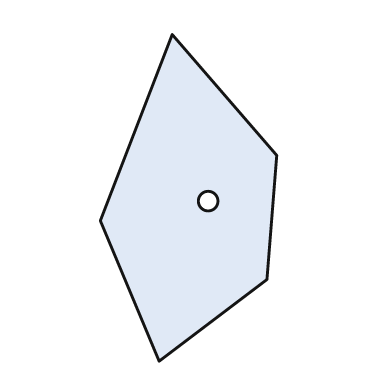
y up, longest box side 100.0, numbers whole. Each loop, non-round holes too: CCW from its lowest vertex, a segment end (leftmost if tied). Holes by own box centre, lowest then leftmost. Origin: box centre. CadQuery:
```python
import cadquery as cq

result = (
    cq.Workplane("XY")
    .moveTo(-9.0, -50.0)
    .lineTo(24.0, -25.0)
    .lineTo(27.0, 13.0)
    .lineTo(-5.0, 50.0)
    .lineTo(-27.0, -7.0)
    .close()
    .moveTo(6.0, -1.0)
    .circle(3.0)
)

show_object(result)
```